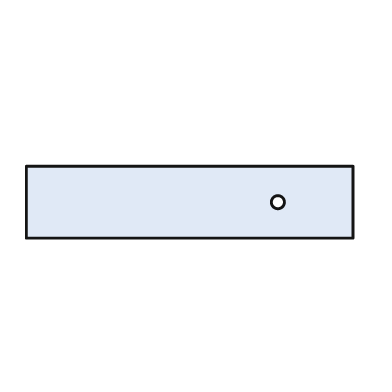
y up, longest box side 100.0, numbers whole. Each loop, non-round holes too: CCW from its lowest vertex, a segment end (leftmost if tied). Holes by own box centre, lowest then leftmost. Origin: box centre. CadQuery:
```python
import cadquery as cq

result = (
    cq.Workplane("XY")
    .moveTo(-50.0, -11.0)
    .lineTo(50.0, -11.0)
    .lineTo(50.0, 11.0)
    .lineTo(-50.0, 11.0)
    .close()
    .moveTo(27.0, 0.0)
    .circle(2.0)
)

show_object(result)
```